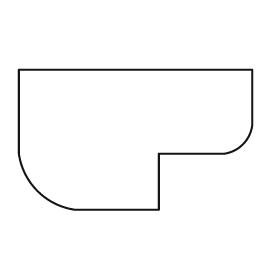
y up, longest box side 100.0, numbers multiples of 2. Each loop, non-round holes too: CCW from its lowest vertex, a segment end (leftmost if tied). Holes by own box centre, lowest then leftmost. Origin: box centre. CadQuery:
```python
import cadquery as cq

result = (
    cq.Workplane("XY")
    .moveTo(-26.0, -30.0)
    .lineTo(10.0, -30.0)
    .lineTo(10.0, -6.0)
    .lineTo(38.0, -6.0)
    .threePointArc((46.0, -2.0), (50.0, 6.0))
    .lineTo(50.0, 30.0)
    .lineTo(-50.0, 30.0)
    .lineTo(-50.0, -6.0)
    .threePointArc((-42.0, -22.0), (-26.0, -30.0))
    .close()
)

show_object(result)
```